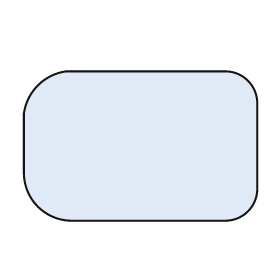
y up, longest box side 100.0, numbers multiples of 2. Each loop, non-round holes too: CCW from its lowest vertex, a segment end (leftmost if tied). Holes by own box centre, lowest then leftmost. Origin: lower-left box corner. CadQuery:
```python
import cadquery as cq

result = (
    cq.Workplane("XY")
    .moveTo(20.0, 0.0)
    .lineTo(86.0, 0.0)
    .threePointArc((96.0, 4.0), (100.0, 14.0))
    .lineTo(100.0, 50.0)
    .threePointArc((96.0, 60.0), (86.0, 64.0))
    .lineTo(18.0, 64.0)
    .threePointArc((6.0, 58.0), (0.0, 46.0))
    .lineTo(0.0, 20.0)
    .threePointArc((6.0, 6.0), (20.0, 0.0))
    .close()
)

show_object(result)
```